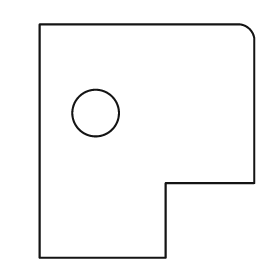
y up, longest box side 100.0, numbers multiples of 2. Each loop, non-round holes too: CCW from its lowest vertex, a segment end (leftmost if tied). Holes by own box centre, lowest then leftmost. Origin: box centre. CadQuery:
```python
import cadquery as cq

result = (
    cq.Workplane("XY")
    .moveTo(-46.0, -50.0)
    .lineTo(8.0, -50.0)
    .lineTo(8.0, -18.0)
    .lineTo(46.0, -18.0)
    .lineTo(46.0, 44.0)
    .threePointArc((44.0, 48.0), (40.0, 50.0))
    .lineTo(-46.0, 50.0)
    .close()
    .moveTo(-22.0, 12.0)
    .circle(10.0)
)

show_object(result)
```